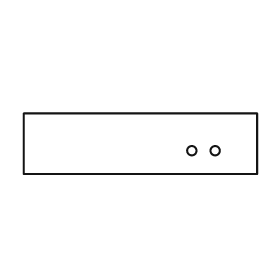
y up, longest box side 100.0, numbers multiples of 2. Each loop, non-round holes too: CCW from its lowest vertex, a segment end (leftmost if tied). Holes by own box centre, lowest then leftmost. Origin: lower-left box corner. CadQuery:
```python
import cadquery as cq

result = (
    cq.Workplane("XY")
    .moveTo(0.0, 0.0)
    .lineTo(100.0, 0.0)
    .lineTo(100.0, 26.0)
    .lineTo(0.0, 26.0)
    .close()
    .moveTo(72.0, 10.0)
    .circle(2.0)
    .moveTo(82.0, 10.0)
    .circle(2.0)
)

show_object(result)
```